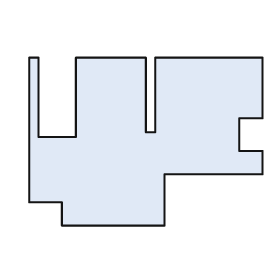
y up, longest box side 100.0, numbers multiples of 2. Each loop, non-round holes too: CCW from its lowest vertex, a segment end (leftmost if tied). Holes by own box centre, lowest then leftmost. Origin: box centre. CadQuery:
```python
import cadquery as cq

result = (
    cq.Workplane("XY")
    .moveTo(-36.0, -36.0)
    .lineTo(8.0, -36.0)
    .lineTo(8.0, -14.0)
    .lineTo(50.0, -14.0)
    .lineTo(50.0, -4.0)
    .lineTo(40.0, -4.0)
    .lineTo(40.0, 10.0)
    .lineTo(50.0, 10.0)
    .lineTo(50.0, 36.0)
    .lineTo(4.0, 36.0)
    .lineTo(4.0, 4.0)
    .lineTo(0.0, 4.0)
    .lineTo(0.0, 36.0)
    .lineTo(-30.0, 36.0)
    .lineTo(-30.0, 2.0)
    .lineTo(-46.0, 2.0)
    .lineTo(-46.0, 36.0)
    .lineTo(-50.0, 36.0)
    .lineTo(-50.0, -26.0)
    .lineTo(-36.0, -26.0)
    .close()
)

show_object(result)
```